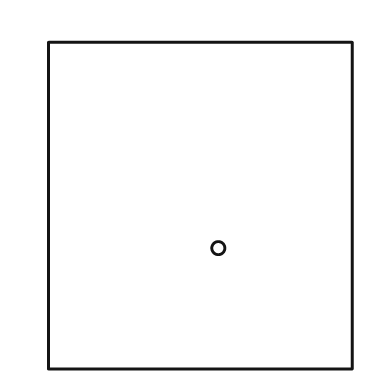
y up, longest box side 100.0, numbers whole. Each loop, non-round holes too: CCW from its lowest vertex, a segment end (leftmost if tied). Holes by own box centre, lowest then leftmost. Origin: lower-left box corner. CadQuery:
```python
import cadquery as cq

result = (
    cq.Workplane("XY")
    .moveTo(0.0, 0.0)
    .lineTo(93.0, 0.0)
    .lineTo(93.0, 100.0)
    .lineTo(0.0, 100.0)
    .close()
    .moveTo(52.0, 37.0)
    .circle(2.0)
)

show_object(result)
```